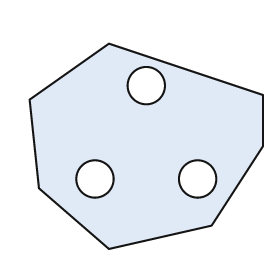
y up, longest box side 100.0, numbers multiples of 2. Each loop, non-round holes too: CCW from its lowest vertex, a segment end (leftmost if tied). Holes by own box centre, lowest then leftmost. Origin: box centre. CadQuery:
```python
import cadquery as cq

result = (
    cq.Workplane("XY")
    .moveTo(-16.0, -44.0)
    .lineTo(28.0, -34.0)
    .lineTo(50.0, 0.0)
    .lineTo(50.0, 22.0)
    .lineTo(-16.0, 44.0)
    .lineTo(-50.0, 20.0)
    .lineTo(-46.0, -18.0)
    .close()
    .moveTo(-22.0, -14.0)
    .circle(8.0)
    .moveTo(22.0, -14.0)
    .circle(8.0)
    .moveTo(0.0, 26.0)
    .circle(8.0)
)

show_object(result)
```